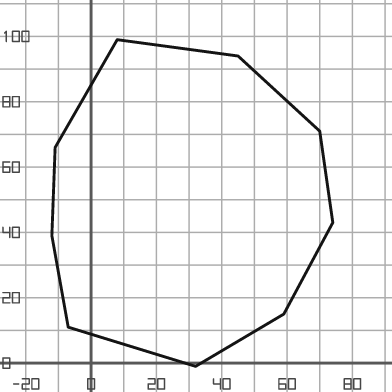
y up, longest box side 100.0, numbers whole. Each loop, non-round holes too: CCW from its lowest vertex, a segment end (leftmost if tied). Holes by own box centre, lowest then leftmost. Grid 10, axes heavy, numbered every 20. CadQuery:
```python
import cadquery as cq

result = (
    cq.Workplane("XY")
    .moveTo(32.0, -1.0)
    .lineTo(59.0, 15.0)
    .lineTo(74.0, 43.0)
    .lineTo(70.0, 71.0)
    .lineTo(45.0, 94.0)
    .lineTo(8.0, 99.0)
    .lineTo(-11.0, 66.0)
    .lineTo(-12.0, 39.0)
    .lineTo(-7.0, 11.0)
    .close()
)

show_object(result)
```